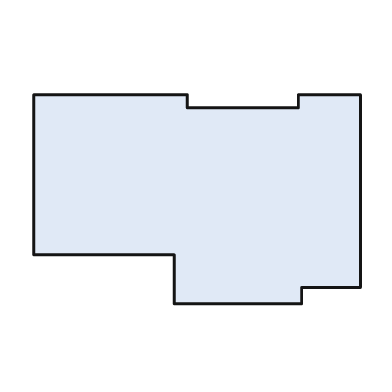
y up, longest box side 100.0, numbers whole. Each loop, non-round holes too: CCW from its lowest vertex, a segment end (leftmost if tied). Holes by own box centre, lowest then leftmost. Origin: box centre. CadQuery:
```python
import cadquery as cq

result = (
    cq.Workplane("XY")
    .moveTo(-7.0, -32.0)
    .lineTo(32.0, -32.0)
    .lineTo(32.0, -27.0)
    .lineTo(50.0, -27.0)
    .lineTo(50.0, 32.0)
    .lineTo(31.0, 32.0)
    .lineTo(31.0, 28.0)
    .lineTo(-3.0, 28.0)
    .lineTo(-3.0, 32.0)
    .lineTo(-50.0, 32.0)
    .lineTo(-50.0, -17.0)
    .lineTo(-7.0, -17.0)
    .close()
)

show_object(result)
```